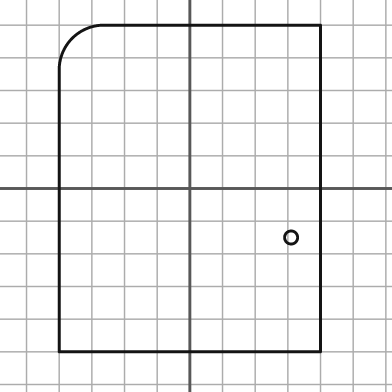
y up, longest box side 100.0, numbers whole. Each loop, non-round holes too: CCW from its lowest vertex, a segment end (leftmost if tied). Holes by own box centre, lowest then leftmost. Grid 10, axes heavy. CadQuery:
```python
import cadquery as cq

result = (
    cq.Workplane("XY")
    .moveTo(-40.0, -50.0)
    .lineTo(40.0, -50.0)
    .lineTo(40.0, 50.0)
    .lineTo(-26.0, 50.0)
    .threePointArc((-36.0, 46.0), (-40.0, 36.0))
    .close()
    .moveTo(31.0, -15.0)
    .circle(2.0)
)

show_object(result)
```